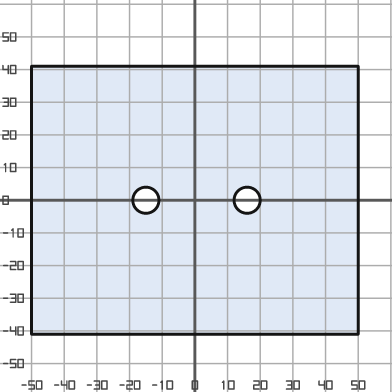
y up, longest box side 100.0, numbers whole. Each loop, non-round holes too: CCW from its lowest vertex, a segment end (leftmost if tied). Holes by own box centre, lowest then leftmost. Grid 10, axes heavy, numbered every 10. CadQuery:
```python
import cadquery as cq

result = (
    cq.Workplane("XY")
    .moveTo(-50.0, -41.0)
    .lineTo(50.0, -41.0)
    .lineTo(50.0, 41.0)
    .lineTo(-50.0, 41.0)
    .close()
    .moveTo(-15.0, 0.0)
    .circle(4.0)
    .moveTo(16.0, 0.0)
    .circle(4.0)
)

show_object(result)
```